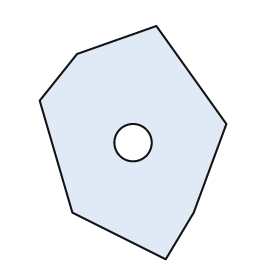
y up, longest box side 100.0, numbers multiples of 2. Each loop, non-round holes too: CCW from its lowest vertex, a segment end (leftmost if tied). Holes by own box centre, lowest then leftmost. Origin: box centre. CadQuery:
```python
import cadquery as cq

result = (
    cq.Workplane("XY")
    .moveTo(14.0, -50.0)
    .lineTo(26.0, -30.0)
    .lineTo(40.0, 8.0)
    .lineTo(10.0, 50.0)
    .lineTo(-24.0, 38.0)
    .lineTo(-40.0, 18.0)
    .lineTo(-26.0, -30.0)
    .close()
    .moveTo(0.0, 0.0)
    .circle(8.0)
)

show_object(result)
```